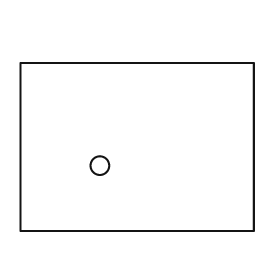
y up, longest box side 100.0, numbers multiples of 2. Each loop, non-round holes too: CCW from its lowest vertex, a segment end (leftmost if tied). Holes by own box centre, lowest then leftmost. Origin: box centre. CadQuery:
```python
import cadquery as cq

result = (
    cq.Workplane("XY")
    .moveTo(-50.0, -36.0)
    .lineTo(50.0, -36.0)
    .lineTo(50.0, 36.0)
    .lineTo(-50.0, 36.0)
    .close()
    .moveTo(-16.0, -8.0)
    .circle(4.0)
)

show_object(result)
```